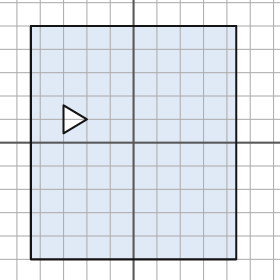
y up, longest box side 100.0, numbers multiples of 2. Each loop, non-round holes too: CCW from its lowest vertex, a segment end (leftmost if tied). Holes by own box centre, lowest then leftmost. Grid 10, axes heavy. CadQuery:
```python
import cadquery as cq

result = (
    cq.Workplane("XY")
    .moveTo(-44.0, -50.0)
    .lineTo(44.0, -50.0)
    .lineTo(44.0, 50.0)
    .lineTo(-44.0, 50.0)
    .close()
    .moveTo(-30.0, 4.0)
    .lineTo(-20.0, 10.0)
    .lineTo(-30.0, 16.0)
    .close()
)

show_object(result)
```